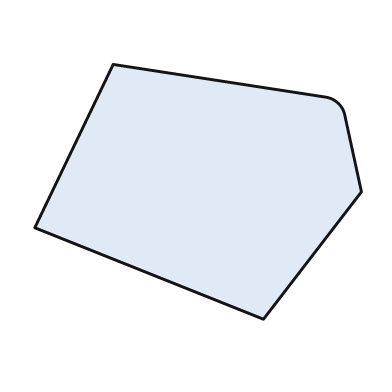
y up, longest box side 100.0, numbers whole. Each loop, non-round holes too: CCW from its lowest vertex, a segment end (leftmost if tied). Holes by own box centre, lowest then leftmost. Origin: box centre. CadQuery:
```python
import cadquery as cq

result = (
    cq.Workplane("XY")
    .moveTo(20.0, -39.0)
    .lineTo(50.0, 0.0)
    .lineTo(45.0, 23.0)
    .threePointArc((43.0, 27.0), (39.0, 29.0))
    .lineTo(-26.0, 39.0)
    .lineTo(-50.0, -11.0)
    .close()
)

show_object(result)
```